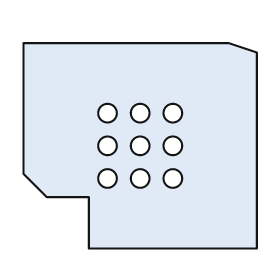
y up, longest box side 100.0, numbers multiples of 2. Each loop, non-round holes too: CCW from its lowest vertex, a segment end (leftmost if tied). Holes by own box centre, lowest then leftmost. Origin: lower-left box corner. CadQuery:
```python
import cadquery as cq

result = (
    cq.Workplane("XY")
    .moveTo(28.0, 0.0)
    .lineTo(100.0, 0.0)
    .lineTo(100.0, 84.0)
    .lineTo(88.0, 88.0)
    .lineTo(0.0, 88.0)
    .lineTo(0.0, 32.0)
    .lineTo(10.0, 22.0)
    .lineTo(28.0, 22.0)
    .close()
    .moveTo(36.0, 30.0)
    .circle(4.0)
    .moveTo(50.0, 30.0)
    .circle(4.0)
    .moveTo(64.0, 30.0)
    .circle(4.0)
    .moveTo(36.0, 44.0)
    .circle(4.0)
    .moveTo(50.0, 44.0)
    .circle(4.0)
    .moveTo(64.0, 44.0)
    .circle(4.0)
    .moveTo(36.0, 58.0)
    .circle(4.0)
    .moveTo(50.0, 58.0)
    .circle(4.0)
    .moveTo(64.0, 58.0)
    .circle(4.0)
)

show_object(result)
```